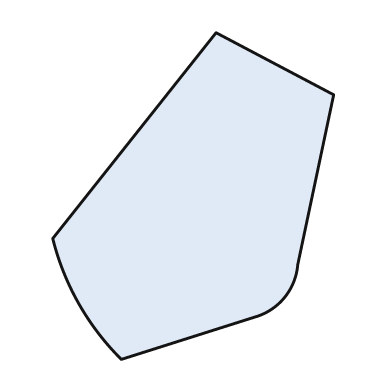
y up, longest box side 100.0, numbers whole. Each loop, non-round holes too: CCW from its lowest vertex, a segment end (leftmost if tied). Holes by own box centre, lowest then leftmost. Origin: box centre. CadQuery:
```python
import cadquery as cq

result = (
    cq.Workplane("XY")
    .moveTo(-22.0, -50.0)
    .lineTo(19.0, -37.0)
    .threePointArc((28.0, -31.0), (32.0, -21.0))
    .lineTo(43.0, 31.0)
    .lineTo(7.0, 50.0)
    .lineTo(-43.0, -13.0)
    .threePointArc((-35.0, -33.0), (-22.0, -50.0))
    .close()
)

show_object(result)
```